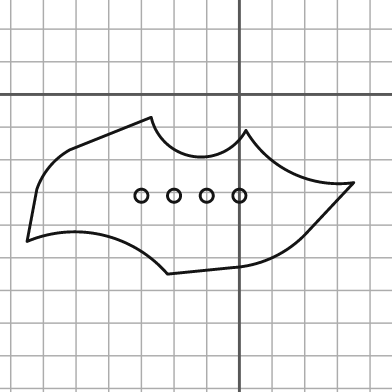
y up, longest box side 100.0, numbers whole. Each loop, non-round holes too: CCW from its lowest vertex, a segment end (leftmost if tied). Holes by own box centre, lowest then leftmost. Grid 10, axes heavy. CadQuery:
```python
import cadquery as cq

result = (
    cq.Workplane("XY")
    .moveTo(-22.0, -55.0)
    .lineTo(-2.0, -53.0)
    .threePointArc((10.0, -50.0), (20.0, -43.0))
    .lineTo(35.0, -27.0)
    .threePointArc((16.0, -24.0), (2.0, -11.0))
    .threePointArc((-14.0, -19.0), (-27.0, -7.0))
    .lineTo(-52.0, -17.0)
    .threePointArc((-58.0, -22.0), (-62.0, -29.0))
    .lineTo(-65.0, -45.0)
    .threePointArc((-42.0, -43.0), (-22.0, -55.0))
    .close()
    .moveTo(-30.0, -31.0)
    .circle(2.0)
    .moveTo(-20.0, -31.0)
    .circle(2.0)
    .moveTo(-10.0, -31.0)
    .circle(2.0)
    .moveTo(0.0, -31.0)
    .circle(2.0)
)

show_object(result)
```